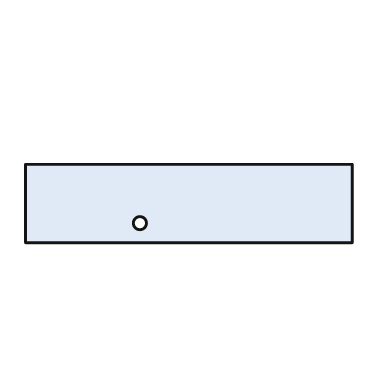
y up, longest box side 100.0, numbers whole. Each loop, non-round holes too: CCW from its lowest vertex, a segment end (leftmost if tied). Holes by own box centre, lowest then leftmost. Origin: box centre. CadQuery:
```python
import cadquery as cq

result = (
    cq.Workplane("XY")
    .moveTo(-50.0, -12.0)
    .lineTo(50.0, -12.0)
    .lineTo(50.0, 12.0)
    .lineTo(-50.0, 12.0)
    .close()
    .moveTo(-15.0, -6.0)
    .circle(2.0)
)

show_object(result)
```